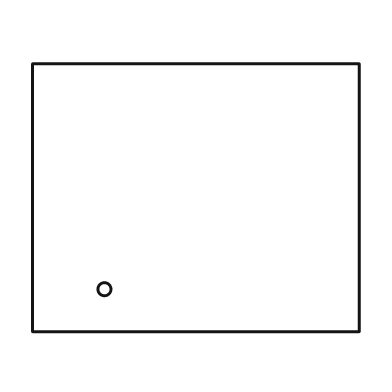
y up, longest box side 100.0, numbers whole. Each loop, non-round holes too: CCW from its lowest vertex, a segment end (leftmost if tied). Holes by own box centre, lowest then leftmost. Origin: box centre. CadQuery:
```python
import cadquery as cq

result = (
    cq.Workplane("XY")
    .moveTo(-50.0, -41.0)
    .lineTo(50.0, -41.0)
    .lineTo(50.0, 41.0)
    .lineTo(-50.0, 41.0)
    .close()
    .moveTo(-28.0, -28.0)
    .circle(2.0)
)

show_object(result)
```